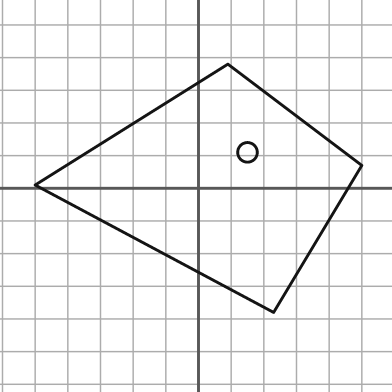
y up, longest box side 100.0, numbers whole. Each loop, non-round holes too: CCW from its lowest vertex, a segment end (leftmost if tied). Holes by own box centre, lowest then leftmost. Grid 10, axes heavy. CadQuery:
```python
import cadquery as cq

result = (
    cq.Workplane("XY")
    .moveTo(23.0, -38.0)
    .lineTo(50.0, 7.0)
    .lineTo(9.0, 38.0)
    .lineTo(-50.0, 1.0)
    .close()
    .moveTo(15.0, 11.0)
    .circle(3.0)
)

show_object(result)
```